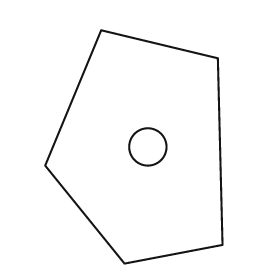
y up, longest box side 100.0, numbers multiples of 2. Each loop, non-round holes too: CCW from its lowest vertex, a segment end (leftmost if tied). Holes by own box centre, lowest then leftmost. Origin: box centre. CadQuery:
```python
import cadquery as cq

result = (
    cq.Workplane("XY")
    .moveTo(-4.0, -50.0)
    .lineTo(38.0, -42.0)
    .lineTo(36.0, 38.0)
    .lineTo(-14.0, 50.0)
    .lineTo(-38.0, -8.0)
    .close()
    .moveTo(6.0, 0.0)
    .circle(8.0)
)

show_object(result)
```